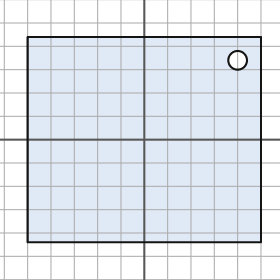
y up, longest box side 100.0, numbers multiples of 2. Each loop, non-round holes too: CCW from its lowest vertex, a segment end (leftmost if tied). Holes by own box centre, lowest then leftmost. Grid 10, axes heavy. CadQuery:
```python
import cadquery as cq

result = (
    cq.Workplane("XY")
    .moveTo(-50.0, -44.0)
    .lineTo(50.0, -44.0)
    .lineTo(50.0, 44.0)
    .lineTo(-50.0, 44.0)
    .close()
    .moveTo(40.0, 34.0)
    .circle(4.0)
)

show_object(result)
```